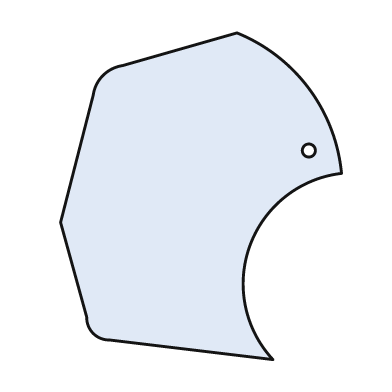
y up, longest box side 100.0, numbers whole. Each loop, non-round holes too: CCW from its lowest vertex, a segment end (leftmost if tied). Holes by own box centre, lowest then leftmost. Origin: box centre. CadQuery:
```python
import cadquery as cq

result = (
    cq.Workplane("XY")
    .moveTo(22.0, -50.0)
    .threePointArc((15.0, -15.0), (43.0, 7.0))
    .threePointArc((33.0, 33.0), (11.0, 50.0))
    .lineTo(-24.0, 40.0)
    .threePointArc((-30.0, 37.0), (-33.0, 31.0))
    .lineTo(-43.0, -8.0)
    .lineTo(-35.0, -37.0)
    .threePointArc((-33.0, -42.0), (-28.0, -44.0))
    .close()
    .moveTo(33.0, 14.0)
    .circle(2.0)
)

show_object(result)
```